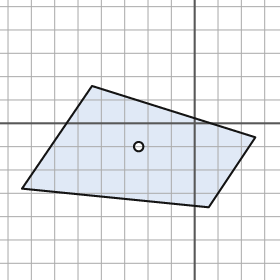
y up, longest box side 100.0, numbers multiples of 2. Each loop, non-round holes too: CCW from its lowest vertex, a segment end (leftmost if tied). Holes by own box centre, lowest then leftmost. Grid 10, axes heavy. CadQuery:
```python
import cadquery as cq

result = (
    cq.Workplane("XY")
    .moveTo(6.0, -36.0)
    .lineTo(26.0, -6.0)
    .lineTo(-44.0, 16.0)
    .lineTo(-74.0, -28.0)
    .close()
    .moveTo(-24.0, -10.0)
    .circle(2.0)
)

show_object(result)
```